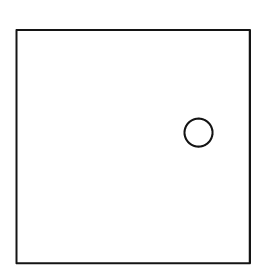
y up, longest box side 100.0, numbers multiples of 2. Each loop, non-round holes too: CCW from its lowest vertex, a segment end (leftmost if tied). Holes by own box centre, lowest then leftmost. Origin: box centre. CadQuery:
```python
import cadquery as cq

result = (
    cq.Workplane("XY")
    .moveTo(-50.0, -50.0)
    .lineTo(50.0, -50.0)
    .lineTo(50.0, 50.0)
    .lineTo(-50.0, 50.0)
    .close()
    .moveTo(28.0, 6.0)
    .circle(6.0)
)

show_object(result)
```